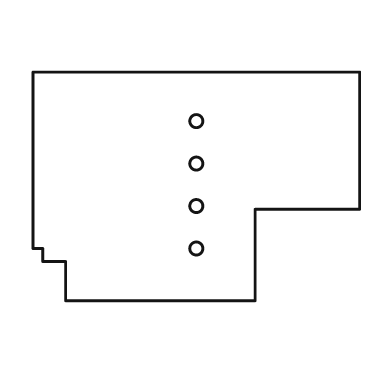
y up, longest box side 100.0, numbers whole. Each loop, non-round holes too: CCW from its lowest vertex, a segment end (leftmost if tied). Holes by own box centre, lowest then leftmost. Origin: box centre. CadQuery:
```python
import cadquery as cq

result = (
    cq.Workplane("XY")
    .moveTo(-40.0, -35.0)
    .lineTo(18.0, -35.0)
    .lineTo(18.0, -7.0)
    .lineTo(50.0, -7.0)
    .lineTo(50.0, 35.0)
    .lineTo(-50.0, 35.0)
    .lineTo(-50.0, -19.0)
    .lineTo(-47.0, -19.0)
    .lineTo(-47.0, -23.0)
    .lineTo(-40.0, -23.0)
    .close()
    .moveTo(0.0, -19.0)
    .circle(2.0)
    .moveTo(0.0, -6.0)
    .circle(2.0)
    .moveTo(0.0, 7.0)
    .circle(2.0)
    .moveTo(0.0, 20.0)
    .circle(2.0)
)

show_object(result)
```